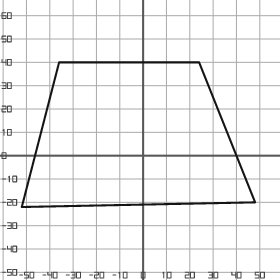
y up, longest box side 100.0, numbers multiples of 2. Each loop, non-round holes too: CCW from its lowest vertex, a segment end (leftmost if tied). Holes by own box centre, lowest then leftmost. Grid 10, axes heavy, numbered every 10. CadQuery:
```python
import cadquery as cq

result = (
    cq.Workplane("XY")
    .moveTo(-52.0, -22.0)
    .lineTo(48.0, -20.0)
    .lineTo(24.0, 40.0)
    .lineTo(-36.0, 40.0)
    .close()
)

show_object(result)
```